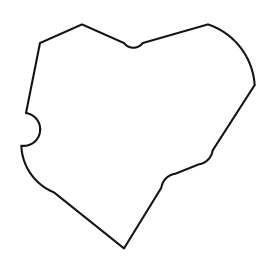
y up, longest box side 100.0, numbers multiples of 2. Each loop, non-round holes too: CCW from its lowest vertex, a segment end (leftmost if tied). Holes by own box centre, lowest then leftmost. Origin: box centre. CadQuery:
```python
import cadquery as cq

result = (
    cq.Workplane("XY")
    .moveTo(-6.0, -48.0)
    .lineTo(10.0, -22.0)
    .threePointArc((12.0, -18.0), (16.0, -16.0))
    .lineTo(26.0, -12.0)
    .threePointArc((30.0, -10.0), (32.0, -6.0))
    .lineTo(50.0, 22.0)
    .threePointArc((44.0, 38.0), (30.0, 48.0))
    .lineTo(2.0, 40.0)
    .threePointArc((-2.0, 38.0), (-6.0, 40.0))
    .lineTo(-24.0, 48.0)
    .lineTo(-42.0, 40.0)
    .lineTo(-48.0, 10.0)
    .threePointArc((-42.0, 2.0), (-50.0, -4.0))
    .threePointArc((-46.0, -16.0), (-36.0, -24.0))
    .close()
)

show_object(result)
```